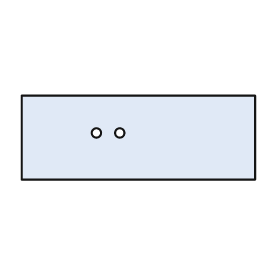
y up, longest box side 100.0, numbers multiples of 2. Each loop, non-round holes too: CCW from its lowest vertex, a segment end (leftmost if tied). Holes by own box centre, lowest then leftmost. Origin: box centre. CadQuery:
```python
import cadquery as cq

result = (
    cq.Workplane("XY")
    .moveTo(-50.0, -18.0)
    .lineTo(50.0, -18.0)
    .lineTo(50.0, 18.0)
    .lineTo(-50.0, 18.0)
    .close()
    .moveTo(-18.0, 2.0)
    .circle(2.0)
    .moveTo(-8.0, 2.0)
    .circle(2.0)
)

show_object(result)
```